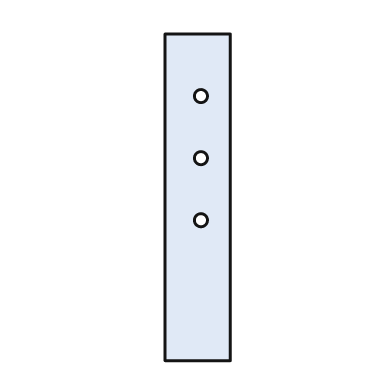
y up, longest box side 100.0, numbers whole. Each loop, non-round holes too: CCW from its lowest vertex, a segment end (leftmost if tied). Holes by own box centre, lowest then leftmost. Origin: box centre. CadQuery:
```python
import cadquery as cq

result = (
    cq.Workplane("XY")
    .moveTo(-10.0, -50.0)
    .lineTo(10.0, -50.0)
    .lineTo(10.0, 50.0)
    .lineTo(-10.0, 50.0)
    .close()
    .moveTo(1.0, -7.0)
    .circle(2.0)
    .moveTo(1.0, 12.0)
    .circle(2.0)
    .moveTo(1.0, 31.0)
    .circle(2.0)
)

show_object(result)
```